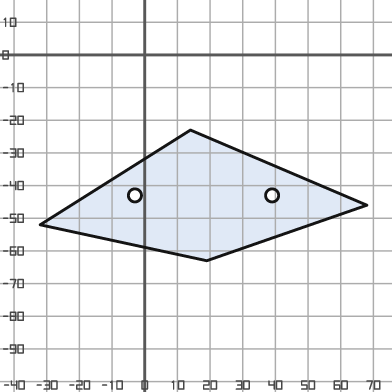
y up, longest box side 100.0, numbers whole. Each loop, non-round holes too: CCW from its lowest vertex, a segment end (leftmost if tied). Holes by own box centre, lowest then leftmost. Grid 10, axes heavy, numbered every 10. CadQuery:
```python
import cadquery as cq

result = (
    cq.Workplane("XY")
    .moveTo(19.0, -63.0)
    .lineTo(68.0, -46.0)
    .lineTo(14.0, -23.0)
    .lineTo(-32.0, -52.0)
    .close()
    .moveTo(-3.0, -43.0)
    .circle(2.0)
    .moveTo(39.0, -43.0)
    .circle(2.0)
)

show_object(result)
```